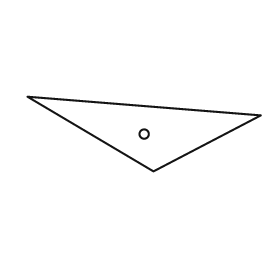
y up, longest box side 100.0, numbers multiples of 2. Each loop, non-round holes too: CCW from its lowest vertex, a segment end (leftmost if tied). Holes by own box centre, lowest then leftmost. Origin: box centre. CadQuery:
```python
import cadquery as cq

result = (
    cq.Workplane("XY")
    .moveTo(4.0, -16.0)
    .lineTo(50.0, 8.0)
    .lineTo(-50.0, 16.0)
    .close()
    .moveTo(0.0, 0.0)
    .circle(2.0)
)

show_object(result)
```